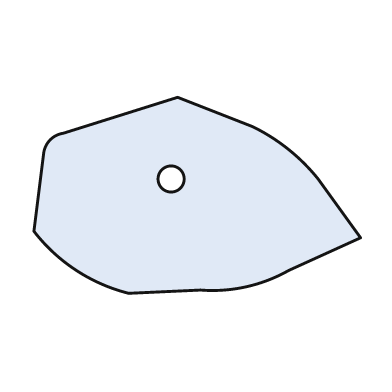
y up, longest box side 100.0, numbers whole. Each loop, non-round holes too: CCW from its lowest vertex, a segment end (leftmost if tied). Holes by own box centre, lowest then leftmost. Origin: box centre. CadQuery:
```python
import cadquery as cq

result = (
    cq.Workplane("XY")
    .moveTo(-21.0, -30.0)
    .lineTo(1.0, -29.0)
    .threePointArc((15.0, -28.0), (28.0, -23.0))
    .lineTo(50.0, -13.0)
    .lineTo(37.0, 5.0)
    .threePointArc((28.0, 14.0), (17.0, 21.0))
    .lineTo(-6.0, 30.0)
    .lineTo(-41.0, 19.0)
    .threePointArc((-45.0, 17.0), (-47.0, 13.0))
    .lineTo(-50.0, -11.0)
    .threePointArc((-37.0, -23.0), (-21.0, -30.0))
    .close()
    .moveTo(-8.0, 5.0)
    .circle(4.0)
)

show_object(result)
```